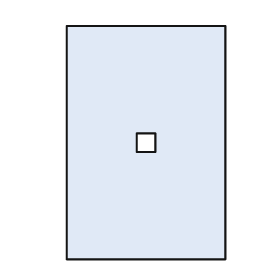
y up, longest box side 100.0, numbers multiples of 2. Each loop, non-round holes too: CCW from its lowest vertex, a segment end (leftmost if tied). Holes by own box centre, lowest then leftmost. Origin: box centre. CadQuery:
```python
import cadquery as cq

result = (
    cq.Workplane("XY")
    .moveTo(-34.0, -50.0)
    .lineTo(34.0, -50.0)
    .lineTo(34.0, 50.0)
    .lineTo(-34.0, 50.0)
    .close()
    .moveTo(-4.0, -4.0)
    .lineTo(4.0, -4.0)
    .lineTo(4.0, 4.0)
    .lineTo(-4.0, 4.0)
    .close()
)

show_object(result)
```